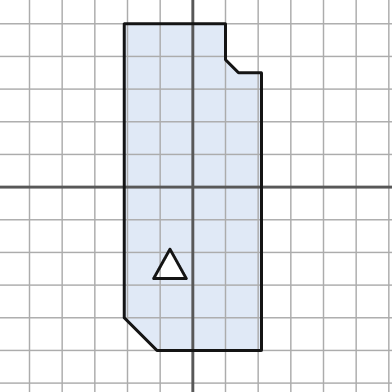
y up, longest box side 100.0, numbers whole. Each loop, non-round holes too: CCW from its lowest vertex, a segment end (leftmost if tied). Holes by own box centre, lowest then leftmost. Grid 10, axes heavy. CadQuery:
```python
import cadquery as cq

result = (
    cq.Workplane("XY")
    .moveTo(-11.0, -50.0)
    .lineTo(21.0, -50.0)
    .lineTo(21.0, 35.0)
    .lineTo(14.0, 35.0)
    .lineTo(10.0, 39.0)
    .lineTo(10.0, 50.0)
    .lineTo(-21.0, 50.0)
    .lineTo(-21.0, -40.0)
    .close()
    .moveTo(-12.0, -28.0)
    .lineTo(-2.0, -28.0)
    .lineTo(-7.0, -19.0)
    .close()
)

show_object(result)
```